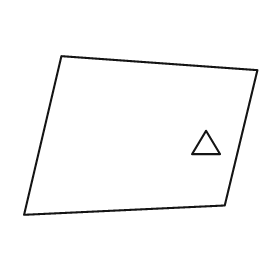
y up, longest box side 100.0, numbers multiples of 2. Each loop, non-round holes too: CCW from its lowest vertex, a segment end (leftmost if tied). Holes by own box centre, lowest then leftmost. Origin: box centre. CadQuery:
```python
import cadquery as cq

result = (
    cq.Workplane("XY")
    .moveTo(-50.0, -34.0)
    .lineTo(36.0, -30.0)
    .lineTo(50.0, 28.0)
    .lineTo(-34.0, 34.0)
    .close()
    .moveTo(22.0, -8.0)
    .lineTo(34.0, -8.0)
    .lineTo(28.0, 2.0)
    .close()
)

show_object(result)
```